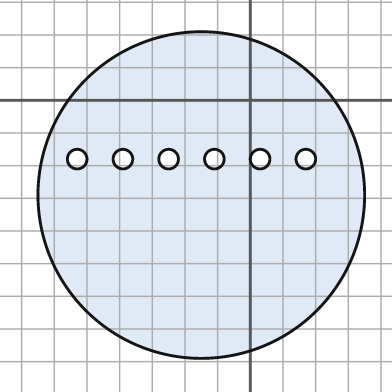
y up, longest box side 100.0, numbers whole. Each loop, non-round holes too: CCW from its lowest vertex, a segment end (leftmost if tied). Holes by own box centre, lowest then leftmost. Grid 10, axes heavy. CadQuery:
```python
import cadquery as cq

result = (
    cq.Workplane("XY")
    .moveTo(-15.0, -29.0)
    .circle(50.0)
    .moveTo(-53.0, -18.0)
    .circle(3.0)
    .moveTo(-39.0, -18.0)
    .circle(3.0)
    .moveTo(-25.0, -18.0)
    .circle(3.0)
    .moveTo(-11.0, -18.0)
    .circle(3.0)
    .moveTo(3.0, -18.0)
    .circle(3.0)
    .moveTo(17.0, -18.0)
    .circle(3.0)
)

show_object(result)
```